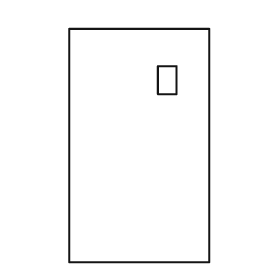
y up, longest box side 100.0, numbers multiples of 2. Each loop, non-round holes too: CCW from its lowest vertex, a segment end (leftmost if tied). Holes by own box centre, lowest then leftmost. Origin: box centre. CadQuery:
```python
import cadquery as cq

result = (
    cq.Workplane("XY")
    .moveTo(-30.0, -50.0)
    .lineTo(30.0, -50.0)
    .lineTo(30.0, 50.0)
    .lineTo(-30.0, 50.0)
    .close()
    .moveTo(8.0, 22.0)
    .lineTo(16.0, 22.0)
    .lineTo(16.0, 34.0)
    .lineTo(8.0, 34.0)
    .close()
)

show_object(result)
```